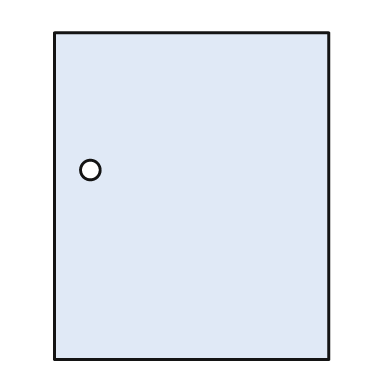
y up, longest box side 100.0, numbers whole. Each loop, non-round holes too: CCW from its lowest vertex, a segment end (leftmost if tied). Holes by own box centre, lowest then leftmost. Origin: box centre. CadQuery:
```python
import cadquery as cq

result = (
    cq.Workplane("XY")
    .moveTo(-42.0, -50.0)
    .lineTo(42.0, -50.0)
    .lineTo(42.0, 50.0)
    .lineTo(-42.0, 50.0)
    .close()
    .moveTo(-31.0, 8.0)
    .circle(3.0)
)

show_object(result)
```